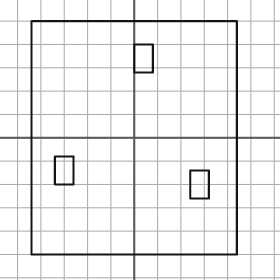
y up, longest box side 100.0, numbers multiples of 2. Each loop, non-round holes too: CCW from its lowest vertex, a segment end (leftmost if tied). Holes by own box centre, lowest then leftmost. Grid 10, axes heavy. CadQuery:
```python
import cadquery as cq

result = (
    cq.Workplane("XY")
    .moveTo(-44.0, -50.0)
    .lineTo(44.0, -50.0)
    .lineTo(44.0, 50.0)
    .lineTo(-44.0, 50.0)
    .close()
    .moveTo(24.0, -26.0)
    .lineTo(32.0, -26.0)
    .lineTo(32.0, -14.0)
    .lineTo(24.0, -14.0)
    .close()
    .moveTo(-34.0, -20.0)
    .lineTo(-26.0, -20.0)
    .lineTo(-26.0, -8.0)
    .lineTo(-34.0, -8.0)
    .close()
    .moveTo(0.0, 28.0)
    .lineTo(8.0, 28.0)
    .lineTo(8.0, 40.0)
    .lineTo(0.0, 40.0)
    .close()
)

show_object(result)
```